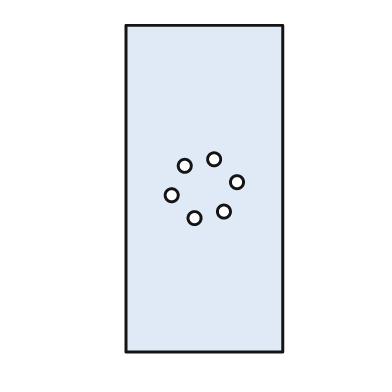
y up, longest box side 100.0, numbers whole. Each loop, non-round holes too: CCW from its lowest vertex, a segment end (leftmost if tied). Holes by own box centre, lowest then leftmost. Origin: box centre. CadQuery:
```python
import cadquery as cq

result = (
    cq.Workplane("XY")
    .moveTo(-24.0, -50.0)
    .lineTo(24.0, -50.0)
    .lineTo(24.0, 50.0)
    .lineTo(-24.0, 50.0)
    .close()
    .moveTo(-3.0, -9.0)
    .circle(2.0)
    .moveTo(6.0, -7.0)
    .circle(2.0)
    .moveTo(-10.0, -2.0)
    .circle(2.0)
    .moveTo(10.0, 2.0)
    .circle(2.0)
    .moveTo(-6.0, 7.0)
    .circle(2.0)
    .moveTo(3.0, 9.0)
    .circle(2.0)
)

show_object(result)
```